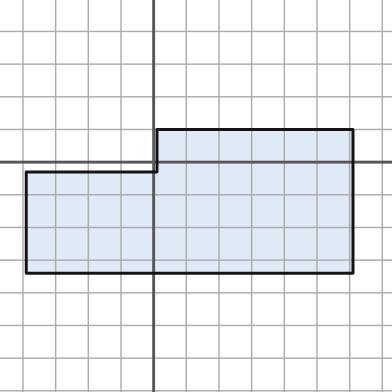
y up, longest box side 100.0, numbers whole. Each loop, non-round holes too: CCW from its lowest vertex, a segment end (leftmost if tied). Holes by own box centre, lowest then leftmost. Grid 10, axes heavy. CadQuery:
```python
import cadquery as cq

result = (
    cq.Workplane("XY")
    .moveTo(-39.0, -34.0)
    .lineTo(61.0, -34.0)
    .lineTo(61.0, 10.0)
    .lineTo(1.0, 10.0)
    .lineTo(1.0, -3.0)
    .lineTo(-39.0, -3.0)
    .close()
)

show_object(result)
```